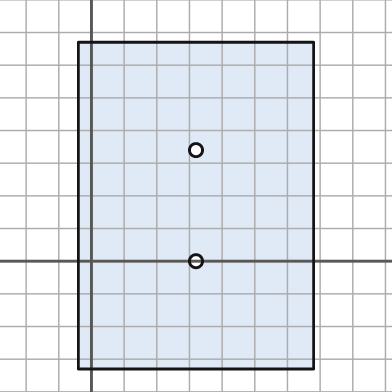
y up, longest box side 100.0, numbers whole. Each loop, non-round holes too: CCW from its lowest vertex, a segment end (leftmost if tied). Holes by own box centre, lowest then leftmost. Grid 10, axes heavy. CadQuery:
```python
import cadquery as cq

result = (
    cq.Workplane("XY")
    .moveTo(-4.0, -33.0)
    .lineTo(68.0, -33.0)
    .lineTo(68.0, 67.0)
    .lineTo(-4.0, 67.0)
    .close()
    .moveTo(32.0, 0.0)
    .circle(2.0)
    .moveTo(32.0, 34.0)
    .circle(2.0)
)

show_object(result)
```